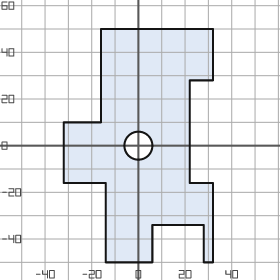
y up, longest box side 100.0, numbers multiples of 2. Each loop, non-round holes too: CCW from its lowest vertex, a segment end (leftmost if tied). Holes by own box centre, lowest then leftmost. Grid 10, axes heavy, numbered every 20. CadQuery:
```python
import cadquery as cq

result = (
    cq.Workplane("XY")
    .moveTo(-14.0, -50.0)
    .lineTo(6.0, -50.0)
    .lineTo(6.0, -34.0)
    .lineTo(28.0, -34.0)
    .lineTo(28.0, -50.0)
    .lineTo(32.0, -50.0)
    .lineTo(32.0, -16.0)
    .lineTo(22.0, -16.0)
    .lineTo(22.0, 28.0)
    .lineTo(32.0, 28.0)
    .lineTo(32.0, 50.0)
    .lineTo(-16.0, 50.0)
    .lineTo(-16.0, 10.0)
    .lineTo(-32.0, 10.0)
    .lineTo(-32.0, -16.0)
    .lineTo(-14.0, -16.0)
    .close()
    .moveTo(0.0, 0.0)
    .circle(6.0)
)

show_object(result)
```